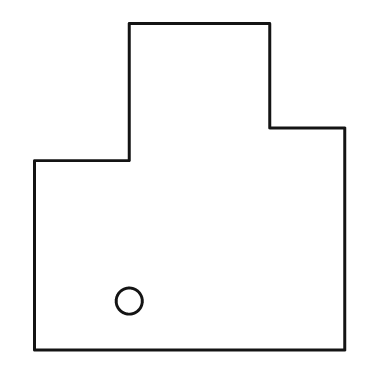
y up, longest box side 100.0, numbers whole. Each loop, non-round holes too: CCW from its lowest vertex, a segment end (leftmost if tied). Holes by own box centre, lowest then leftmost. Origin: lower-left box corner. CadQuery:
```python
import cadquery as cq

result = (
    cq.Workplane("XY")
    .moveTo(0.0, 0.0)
    .lineTo(95.0, 0.0)
    .lineTo(95.0, 68.0)
    .lineTo(72.0, 68.0)
    .lineTo(72.0, 100.0)
    .lineTo(29.0, 100.0)
    .lineTo(29.0, 58.0)
    .lineTo(0.0, 58.0)
    .close()
    .moveTo(29.0, 15.0)
    .circle(4.0)
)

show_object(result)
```